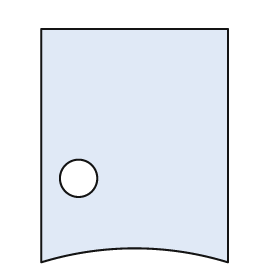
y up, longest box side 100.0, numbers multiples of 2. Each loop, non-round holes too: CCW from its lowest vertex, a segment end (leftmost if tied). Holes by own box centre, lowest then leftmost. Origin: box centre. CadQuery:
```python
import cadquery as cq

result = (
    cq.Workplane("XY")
    .moveTo(-40.0, -50.0)
    .threePointArc((0.0, -44.0), (40.0, -50.0))
    .lineTo(40.0, 50.0)
    .lineTo(-40.0, 50.0)
    .close()
    .moveTo(-24.0, -14.0)
    .circle(8.0)
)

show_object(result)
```